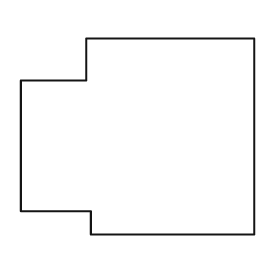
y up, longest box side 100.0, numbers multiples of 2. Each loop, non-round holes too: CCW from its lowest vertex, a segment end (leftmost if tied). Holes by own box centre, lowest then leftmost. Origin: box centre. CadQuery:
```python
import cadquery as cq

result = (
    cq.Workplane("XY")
    .moveTo(-20.0, -42.0)
    .lineTo(50.0, -42.0)
    .lineTo(50.0, 42.0)
    .lineTo(-22.0, 42.0)
    .lineTo(-22.0, 24.0)
    .lineTo(-50.0, 24.0)
    .lineTo(-50.0, -32.0)
    .lineTo(-20.0, -32.0)
    .close()
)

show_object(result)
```